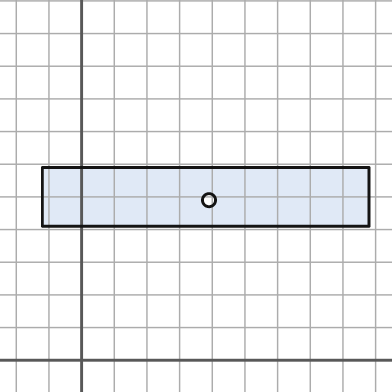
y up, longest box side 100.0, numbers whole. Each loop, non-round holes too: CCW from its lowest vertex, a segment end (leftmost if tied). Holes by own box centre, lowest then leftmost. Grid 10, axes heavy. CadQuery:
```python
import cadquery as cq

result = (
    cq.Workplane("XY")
    .moveTo(-12.0, 41.0)
    .lineTo(88.0, 41.0)
    .lineTo(88.0, 59.0)
    .lineTo(-12.0, 59.0)
    .close()
    .moveTo(39.0, 49.0)
    .circle(2.0)
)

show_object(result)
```